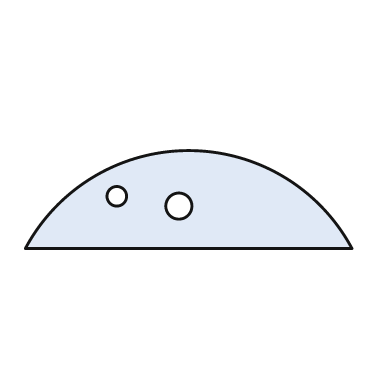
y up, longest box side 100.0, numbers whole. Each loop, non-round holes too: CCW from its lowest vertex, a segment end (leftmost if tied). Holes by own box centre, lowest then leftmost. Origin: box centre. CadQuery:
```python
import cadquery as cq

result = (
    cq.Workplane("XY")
    .moveTo(-50.0, -15.0)
    .lineTo(50.0, -15.0)
    .threePointArc((0.0, 15.0), (-50.0, -15.0))
    .close()
    .moveTo(-3.0, -2.0)
    .circle(4.0)
    .moveTo(-22.0, 1.0)
    .circle(3.0)
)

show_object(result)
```